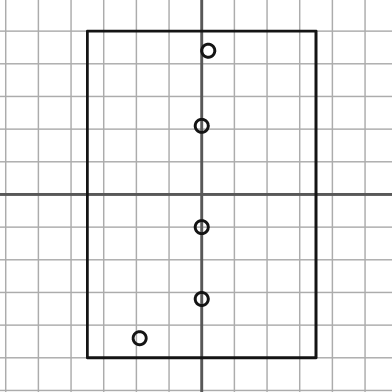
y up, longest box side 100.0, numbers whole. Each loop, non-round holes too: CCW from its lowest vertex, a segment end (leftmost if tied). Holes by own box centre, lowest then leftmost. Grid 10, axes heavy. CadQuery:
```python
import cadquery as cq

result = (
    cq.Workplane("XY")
    .moveTo(-35.0, -50.0)
    .lineTo(35.0, -50.0)
    .lineTo(35.0, 50.0)
    .lineTo(-35.0, 50.0)
    .close()
    .moveTo(-19.0, -44.0)
    .circle(2.0)
    .moveTo(0.0, -32.0)
    .circle(2.0)
    .moveTo(0.0, -10.0)
    .circle(2.0)
    .moveTo(0.0, 21.0)
    .circle(2.0)
    .moveTo(2.0, 44.0)
    .circle(2.0)
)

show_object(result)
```